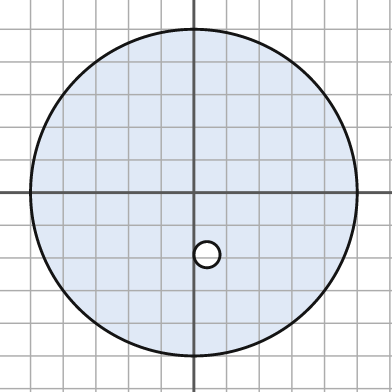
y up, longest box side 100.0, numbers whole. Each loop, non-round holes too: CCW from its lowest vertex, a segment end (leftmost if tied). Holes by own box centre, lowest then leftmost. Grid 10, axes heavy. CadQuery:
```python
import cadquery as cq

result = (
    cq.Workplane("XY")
    .moveTo(0.0, 0.0)
    .circle(50.0)
    .moveTo(4.0, -19.0)
    .circle(4.0)
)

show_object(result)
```